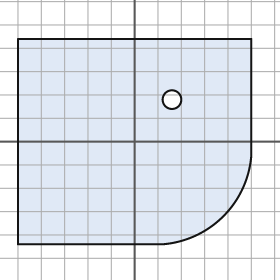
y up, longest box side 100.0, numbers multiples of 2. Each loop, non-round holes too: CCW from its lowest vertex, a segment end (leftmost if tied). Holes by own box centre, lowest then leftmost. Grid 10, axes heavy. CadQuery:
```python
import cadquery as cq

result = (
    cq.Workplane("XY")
    .moveTo(-50.0, -44.0)
    .lineTo(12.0, -44.0)
    .threePointArc((38.0, -32.0), (50.0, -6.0))
    .lineTo(50.0, 44.0)
    .lineTo(-50.0, 44.0)
    .close()
    .moveTo(16.0, 18.0)
    .circle(4.0)
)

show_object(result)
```